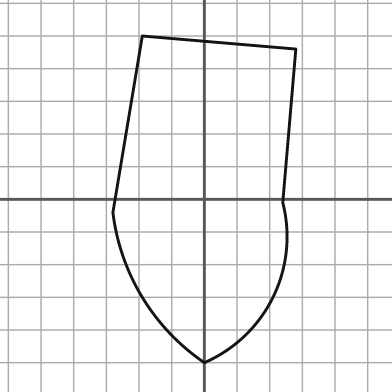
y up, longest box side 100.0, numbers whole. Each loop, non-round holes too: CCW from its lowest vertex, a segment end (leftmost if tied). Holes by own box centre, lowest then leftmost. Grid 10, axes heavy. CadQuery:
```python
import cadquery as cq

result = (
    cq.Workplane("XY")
    .moveTo(0.0, -50.0)
    .threePointArc((21.0, -30.0), (24.0, -1.0))
    .lineTo(28.0, 46.0)
    .lineTo(-19.0, 50.0)
    .lineTo(-28.0, -4.0)
    .threePointArc((-19.0, -30.0), (0.0, -50.0))
    .close()
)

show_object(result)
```